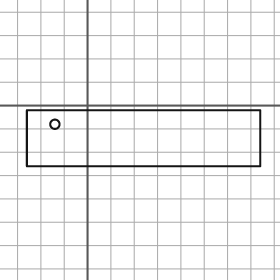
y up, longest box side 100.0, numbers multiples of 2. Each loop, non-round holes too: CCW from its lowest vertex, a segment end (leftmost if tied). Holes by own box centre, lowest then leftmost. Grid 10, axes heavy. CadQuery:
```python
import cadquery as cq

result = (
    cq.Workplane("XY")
    .moveTo(-26.0, -26.0)
    .lineTo(74.0, -26.0)
    .lineTo(74.0, -2.0)
    .lineTo(-26.0, -2.0)
    .close()
    .moveTo(-14.0, -8.0)
    .circle(2.0)
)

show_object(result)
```